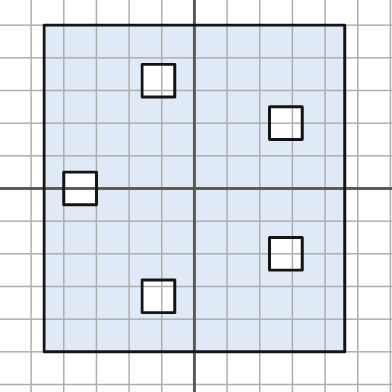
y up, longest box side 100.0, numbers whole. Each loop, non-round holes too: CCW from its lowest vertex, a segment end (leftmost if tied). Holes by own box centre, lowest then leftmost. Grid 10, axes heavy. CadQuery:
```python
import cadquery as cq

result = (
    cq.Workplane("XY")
    .moveTo(-46.0, -50.0)
    .lineTo(46.0, -50.0)
    .lineTo(46.0, 50.0)
    .lineTo(-46.0, 50.0)
    .close()
    .moveTo(-16.0, -38.0)
    .lineTo(-6.0, -38.0)
    .lineTo(-6.0, -28.0)
    .lineTo(-16.0, -28.0)
    .close()
    .moveTo(23.0, -25.0)
    .lineTo(33.0, -25.0)
    .lineTo(33.0, -15.0)
    .lineTo(23.0, -15.0)
    .close()
    .moveTo(-40.0, -5.0)
    .lineTo(-30.0, -5.0)
    .lineTo(-30.0, 5.0)
    .lineTo(-40.0, 5.0)
    .close()
    .moveTo(23.0, 15.0)
    .lineTo(33.0, 15.0)
    .lineTo(33.0, 25.0)
    .lineTo(23.0, 25.0)
    .close()
    .moveTo(-16.0, 28.0)
    .lineTo(-6.0, 28.0)
    .lineTo(-6.0, 38.0)
    .lineTo(-16.0, 38.0)
    .close()
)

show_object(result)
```